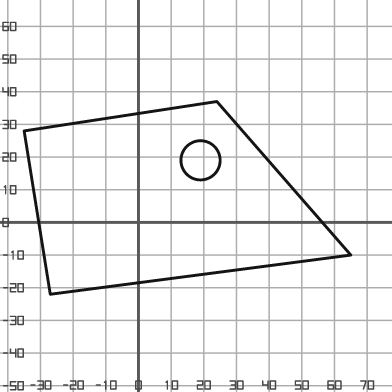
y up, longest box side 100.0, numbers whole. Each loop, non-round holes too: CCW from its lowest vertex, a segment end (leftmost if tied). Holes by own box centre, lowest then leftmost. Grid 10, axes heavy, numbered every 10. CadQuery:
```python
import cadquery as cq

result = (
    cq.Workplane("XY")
    .moveTo(-27.0, -22.0)
    .lineTo(65.0, -10.0)
    .lineTo(24.0, 37.0)
    .lineTo(-35.0, 28.0)
    .close()
    .moveTo(19.0, 19.0)
    .circle(6.0)
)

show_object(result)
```